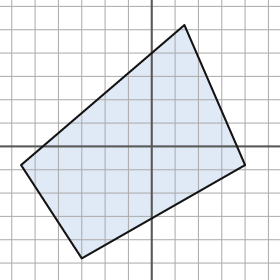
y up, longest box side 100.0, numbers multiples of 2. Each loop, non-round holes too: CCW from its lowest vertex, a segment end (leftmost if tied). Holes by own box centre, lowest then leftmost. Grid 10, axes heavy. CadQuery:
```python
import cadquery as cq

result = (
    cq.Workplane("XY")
    .moveTo(-30.0, -48.0)
    .lineTo(40.0, -8.0)
    .lineTo(14.0, 52.0)
    .lineTo(-56.0, -8.0)
    .close()
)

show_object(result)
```